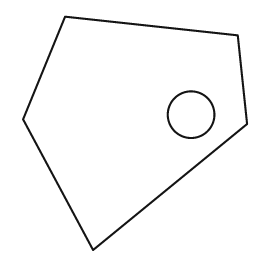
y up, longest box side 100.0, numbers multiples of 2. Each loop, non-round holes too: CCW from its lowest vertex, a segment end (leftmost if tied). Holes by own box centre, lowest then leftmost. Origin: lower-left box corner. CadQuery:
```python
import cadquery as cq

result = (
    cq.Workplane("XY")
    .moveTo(30.0, 0.0)
    .lineTo(96.0, 54.0)
    .lineTo(92.0, 92.0)
    .lineTo(18.0, 100.0)
    .lineTo(0.0, 56.0)
    .close()
    .moveTo(72.0, 58.0)
    .circle(10.0)
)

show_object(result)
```